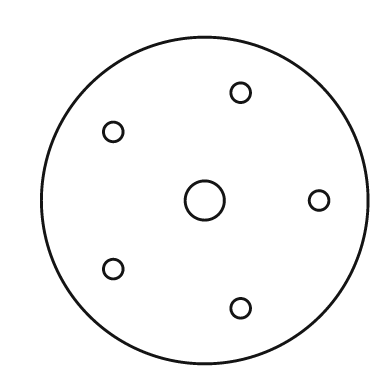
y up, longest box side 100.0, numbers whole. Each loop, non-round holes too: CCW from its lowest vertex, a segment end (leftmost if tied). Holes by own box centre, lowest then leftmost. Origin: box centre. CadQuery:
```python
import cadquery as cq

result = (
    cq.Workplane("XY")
    .moveTo(0.0, 0.0)
    .circle(50.0)
    .moveTo(11.0, -33.0)
    .circle(3.0)
    .moveTo(-28.0, -21.0)
    .circle(3.0)
    .moveTo(0.0, 0.0)
    .circle(6.0)
    .moveTo(35.0, 0.0)
    .circle(3.0)
    .moveTo(-28.0, 21.0)
    .circle(3.0)
    .moveTo(11.0, 33.0)
    .circle(3.0)
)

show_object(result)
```